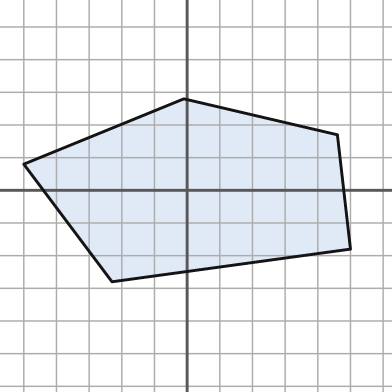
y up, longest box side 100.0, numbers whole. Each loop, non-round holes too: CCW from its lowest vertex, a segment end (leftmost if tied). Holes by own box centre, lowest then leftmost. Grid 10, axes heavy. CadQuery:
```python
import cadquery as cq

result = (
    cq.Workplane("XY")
    .moveTo(-23.0, -28.0)
    .lineTo(50.0, -18.0)
    .lineTo(46.0, 17.0)
    .lineTo(-1.0, 28.0)
    .lineTo(-50.0, 8.0)
    .close()
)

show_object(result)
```